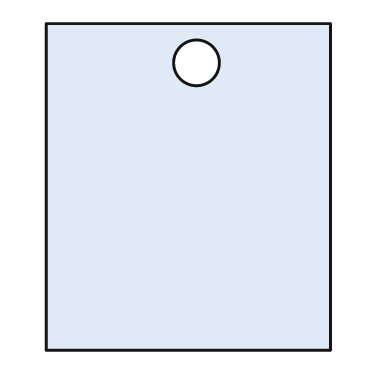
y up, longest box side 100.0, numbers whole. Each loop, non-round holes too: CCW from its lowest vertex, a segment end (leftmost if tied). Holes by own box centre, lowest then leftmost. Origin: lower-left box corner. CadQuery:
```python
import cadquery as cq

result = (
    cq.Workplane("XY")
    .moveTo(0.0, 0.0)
    .lineTo(87.0, 0.0)
    .lineTo(87.0, 100.0)
    .lineTo(0.0, 100.0)
    .close()
    .moveTo(46.0, 88.0)
    .circle(7.0)
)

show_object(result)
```